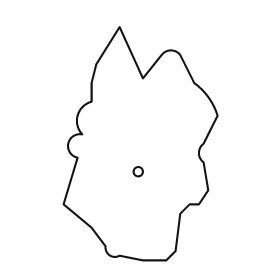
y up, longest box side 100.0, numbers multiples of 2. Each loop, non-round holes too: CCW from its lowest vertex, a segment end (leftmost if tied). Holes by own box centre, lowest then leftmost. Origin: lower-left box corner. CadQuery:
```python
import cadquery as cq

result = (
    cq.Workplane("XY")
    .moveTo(34.0, 0.0)
    .lineTo(44.0, 0.0)
    .lineTo(48.0, 4.0)
    .lineTo(50.0, 20.0)
    .lineTo(54.0, 24.0)
    .lineTo(58.0, 24.0)
    .lineTo(62.0, 30.0)
    .lineTo(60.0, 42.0)
    .threePointArc((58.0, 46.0), (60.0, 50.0))
    .lineTo(66.0, 62.0)
    .threePointArc((62.0, 70.0), (56.0, 76.0))
    .lineTo(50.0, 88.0)
    .threePointArc((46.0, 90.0), (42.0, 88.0))
    .lineTo(34.0, 78.0)
    .lineTo(24.0, 100.0)
    .lineTo(14.0, 84.0)
    .lineTo(12.0, 76.0)
    .lineTo(12.0, 68.0)
    .threePointArc((6.0, 62.0), (8.0, 54.0))
    .threePointArc((2.0, 50.0), (6.0, 44.0))
    .lineTo(0.0, 24.0)
    .lineTo(12.0, 14.0)
    .lineTo(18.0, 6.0)
    .threePointArc((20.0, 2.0), (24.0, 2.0))
    .close()
    .moveTo(32.0, 38.0)
    .circle(2.0)
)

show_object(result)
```